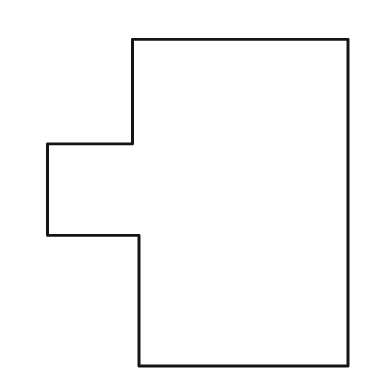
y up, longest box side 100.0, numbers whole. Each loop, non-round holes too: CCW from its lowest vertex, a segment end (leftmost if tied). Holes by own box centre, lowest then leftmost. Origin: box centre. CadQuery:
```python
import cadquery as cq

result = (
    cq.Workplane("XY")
    .moveTo(-18.0, -50.0)
    .lineTo(46.0, -50.0)
    .lineTo(46.0, 50.0)
    .lineTo(-20.0, 50.0)
    .lineTo(-20.0, 18.0)
    .lineTo(-46.0, 18.0)
    .lineTo(-46.0, -10.0)
    .lineTo(-18.0, -10.0)
    .close()
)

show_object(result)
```